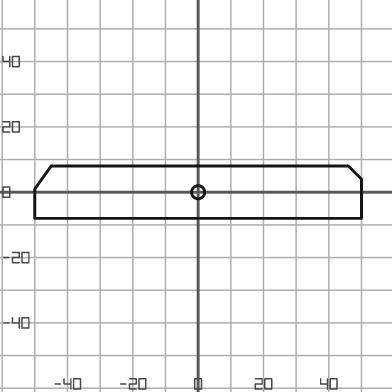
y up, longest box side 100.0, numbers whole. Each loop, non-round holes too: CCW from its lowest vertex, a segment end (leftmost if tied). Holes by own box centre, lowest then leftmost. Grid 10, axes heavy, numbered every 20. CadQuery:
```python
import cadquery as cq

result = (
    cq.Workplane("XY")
    .moveTo(-50.0, -8.0)
    .lineTo(50.0, -8.0)
    .lineTo(50.0, 4.0)
    .lineTo(46.0, 8.0)
    .lineTo(-45.0, 8.0)
    .lineTo(-50.0, 1.0)
    .close()
    .moveTo(0.0, 0.0)
    .circle(2.0)
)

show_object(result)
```